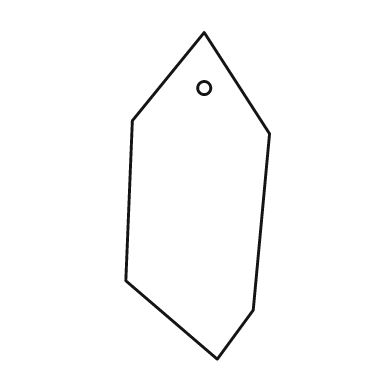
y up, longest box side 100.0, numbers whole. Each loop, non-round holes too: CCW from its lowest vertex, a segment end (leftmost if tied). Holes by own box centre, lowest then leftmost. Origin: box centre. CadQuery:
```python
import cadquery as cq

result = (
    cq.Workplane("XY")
    .moveTo(6.0, -50.0)
    .lineTo(17.0, -35.0)
    .lineTo(22.0, 19.0)
    .lineTo(2.0, 50.0)
    .lineTo(-20.0, 23.0)
    .lineTo(-22.0, -26.0)
    .close()
    .moveTo(2.0, 33.0)
    .circle(2.0)
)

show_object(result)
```